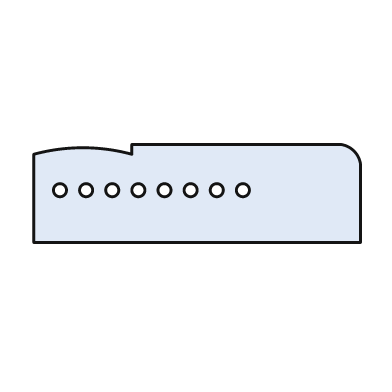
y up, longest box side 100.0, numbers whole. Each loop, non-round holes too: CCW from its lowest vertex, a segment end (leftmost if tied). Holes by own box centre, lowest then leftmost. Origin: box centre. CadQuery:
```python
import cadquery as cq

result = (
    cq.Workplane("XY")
    .moveTo(-50.0, -15.0)
    .lineTo(50.0, -15.0)
    .lineTo(50.0, 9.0)
    .threePointArc((48.0, 13.0), (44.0, 15.0))
    .lineTo(-20.0, 15.0)
    .lineTo(-20.0, 12.0)
    .threePointArc((-35.0, 14.0), (-50.0, 12.0))
    .close()
    .moveTo(-42.0, 1.0)
    .circle(2.0)
    .moveTo(-34.0, 1.0)
    .circle(2.0)
    .moveTo(-26.0, 1.0)
    .circle(2.0)
    .moveTo(-18.0, 1.0)
    .circle(2.0)
    .moveTo(-10.0, 1.0)
    .circle(2.0)
    .moveTo(-2.0, 1.0)
    .circle(2.0)
    .moveTo(6.0, 1.0)
    .circle(2.0)
    .moveTo(14.0, 1.0)
    .circle(2.0)
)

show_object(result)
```